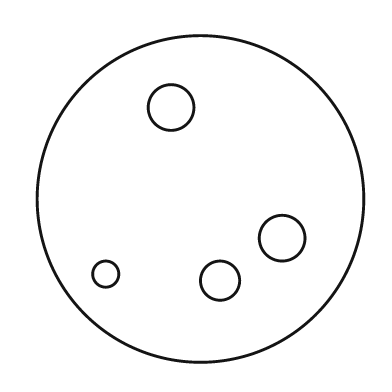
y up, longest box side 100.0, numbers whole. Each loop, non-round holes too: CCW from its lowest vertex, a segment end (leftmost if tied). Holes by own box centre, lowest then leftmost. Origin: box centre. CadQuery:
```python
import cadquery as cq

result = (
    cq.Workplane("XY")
    .moveTo(0.0, 0.0)
    .circle(50.0)
    .moveTo(6.0, -25.0)
    .circle(6.0)
    .moveTo(-29.0, -23.0)
    .circle(4.0)
    .moveTo(25.0, -12.0)
    .circle(7.0)
    .moveTo(-9.0, 28.0)
    .circle(7.0)
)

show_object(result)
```